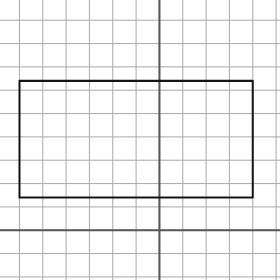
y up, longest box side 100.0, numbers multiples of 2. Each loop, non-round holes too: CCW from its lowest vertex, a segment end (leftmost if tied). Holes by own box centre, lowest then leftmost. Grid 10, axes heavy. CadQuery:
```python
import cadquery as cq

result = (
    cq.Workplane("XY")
    .moveTo(-60.0, 14.0)
    .lineTo(40.0, 14.0)
    .lineTo(40.0, 64.0)
    .lineTo(-60.0, 64.0)
    .close()
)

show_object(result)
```